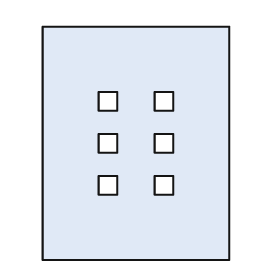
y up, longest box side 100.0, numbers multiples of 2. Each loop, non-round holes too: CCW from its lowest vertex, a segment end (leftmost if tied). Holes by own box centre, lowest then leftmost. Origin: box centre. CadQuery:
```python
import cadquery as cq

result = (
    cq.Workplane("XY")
    .moveTo(-40.0, -50.0)
    .lineTo(40.0, -50.0)
    .lineTo(40.0, 50.0)
    .lineTo(-40.0, 50.0)
    .close()
    .moveTo(-16.0, -22.0)
    .lineTo(-8.0, -22.0)
    .lineTo(-8.0, -14.0)
    .lineTo(-16.0, -14.0)
    .close()
    .moveTo(8.0, -22.0)
    .lineTo(16.0, -22.0)
    .lineTo(16.0, -14.0)
    .lineTo(8.0, -14.0)
    .close()
    .moveTo(-16.0, -4.0)
    .lineTo(-8.0, -4.0)
    .lineTo(-8.0, 4.0)
    .lineTo(-16.0, 4.0)
    .close()
    .moveTo(8.0, -4.0)
    .lineTo(16.0, -4.0)
    .lineTo(16.0, 4.0)
    .lineTo(8.0, 4.0)
    .close()
    .moveTo(-16.0, 14.0)
    .lineTo(-8.0, 14.0)
    .lineTo(-8.0, 22.0)
    .lineTo(-16.0, 22.0)
    .close()
    .moveTo(8.0, 14.0)
    .lineTo(16.0, 14.0)
    .lineTo(16.0, 22.0)
    .lineTo(8.0, 22.0)
    .close()
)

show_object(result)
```